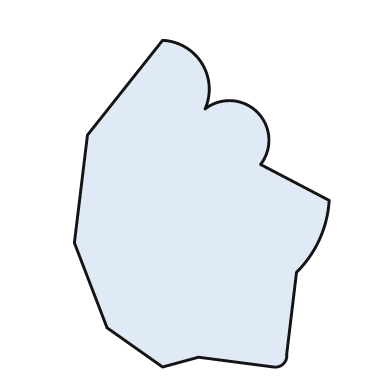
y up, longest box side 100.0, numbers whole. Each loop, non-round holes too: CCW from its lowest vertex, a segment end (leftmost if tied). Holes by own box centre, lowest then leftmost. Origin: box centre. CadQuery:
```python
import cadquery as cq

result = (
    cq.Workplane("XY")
    .moveTo(-12.0, -50.0)
    .lineTo(-1.0, -47.0)
    .lineTo(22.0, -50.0)
    .threePointArc((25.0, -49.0), (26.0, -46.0))
    .lineTo(29.0, -21.0)
    .threePointArc((36.0, -11.0), (39.0, 1.0))
    .lineTo(18.0, 12.0)
    .threePointArc((17.0, 28.0), (1.0, 29.0))
    .threePointArc((0.0, 43.0), (-12.0, 50.0))
    .lineTo(-35.0, 21.0)
    .lineTo(-39.0, -12.0)
    .lineTo(-29.0, -38.0)
    .close()
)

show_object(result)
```